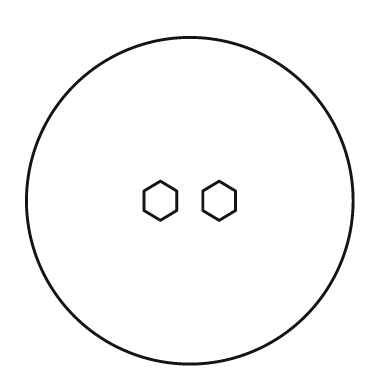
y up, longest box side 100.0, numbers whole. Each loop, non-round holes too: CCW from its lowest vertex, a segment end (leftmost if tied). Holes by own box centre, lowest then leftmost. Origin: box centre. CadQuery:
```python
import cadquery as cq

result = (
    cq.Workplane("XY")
    .moveTo(0.0, 0.0)
    .circle(50.0)
    .moveTo(-9.0, -6.0)
    .lineTo(-4.0, -3.0)
    .lineTo(-4.0, 3.0)
    .lineTo(-9.0, 6.0)
    .lineTo(-14.0, 3.0)
    .lineTo(-14.0, -3.0)
    .close()
    .moveTo(9.0, -6.0)
    .lineTo(14.0, -3.0)
    .lineTo(14.0, 3.0)
    .lineTo(9.0, 6.0)
    .lineTo(4.0, 3.0)
    .lineTo(4.0, -3.0)
    .close()
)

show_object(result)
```